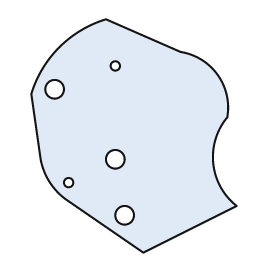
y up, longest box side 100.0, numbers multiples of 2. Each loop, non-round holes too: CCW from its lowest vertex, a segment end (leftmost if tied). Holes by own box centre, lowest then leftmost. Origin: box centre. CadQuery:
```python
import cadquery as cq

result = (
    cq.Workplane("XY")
    .moveTo(4.0, -50.0)
    .lineTo(44.0, -30.0)
    .threePointArc((34.0, -12.0), (40.0, 8.0))
    .threePointArc((36.0, 26.0), (20.0, 36.0))
    .lineTo(-12.0, 50.0)
    .threePointArc((-32.0, 38.0), (-44.0, 18.0))
    .lineTo(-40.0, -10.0)
    .threePointArc((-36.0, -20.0), (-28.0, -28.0))
    .close()
    .moveTo(-4.0, -34.0)
    .circle(4.0)
    .moveTo(-28.0, -20.0)
    .circle(2.0)
    .moveTo(-8.0, -10.0)
    .circle(4.0)
    .moveTo(-34.0, 20.0)
    .circle(4.0)
    .moveTo(-8.0, 30.0)
    .circle(2.0)
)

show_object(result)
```